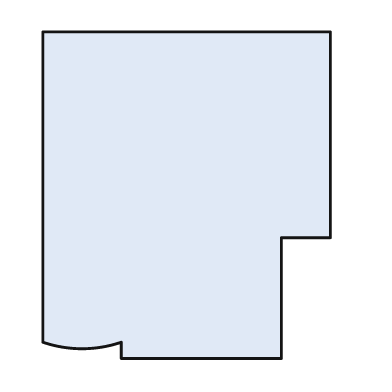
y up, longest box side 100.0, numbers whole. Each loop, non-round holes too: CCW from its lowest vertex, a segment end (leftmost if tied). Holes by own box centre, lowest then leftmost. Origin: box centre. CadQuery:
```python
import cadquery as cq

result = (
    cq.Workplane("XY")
    .moveTo(-20.0, -50.0)
    .lineTo(29.0, -50.0)
    .lineTo(29.0, -13.0)
    .lineTo(44.0, -13.0)
    .lineTo(44.0, 50.0)
    .lineTo(-44.0, 50.0)
    .lineTo(-44.0, -45.0)
    .threePointArc((-32.0, -47.0), (-20.0, -45.0))
    .close()
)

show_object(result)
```